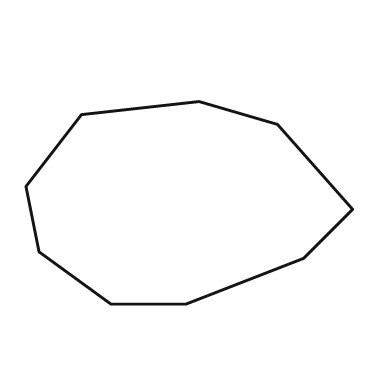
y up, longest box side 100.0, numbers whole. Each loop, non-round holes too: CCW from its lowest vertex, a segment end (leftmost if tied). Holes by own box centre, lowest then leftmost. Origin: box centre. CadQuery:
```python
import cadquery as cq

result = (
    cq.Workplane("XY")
    .moveTo(-24.0, -31.0)
    .lineTo(-1.0, -31.0)
    .lineTo(35.0, -17.0)
    .lineTo(50.0, -2.0)
    .lineTo(27.0, 24.0)
    .lineTo(3.0, 31.0)
    .lineTo(-33.0, 27.0)
    .lineTo(-50.0, 5.0)
    .lineTo(-46.0, -15.0)
    .close()
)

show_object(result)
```